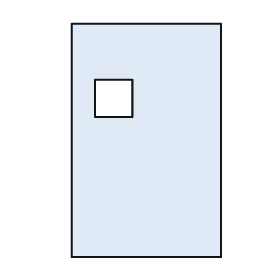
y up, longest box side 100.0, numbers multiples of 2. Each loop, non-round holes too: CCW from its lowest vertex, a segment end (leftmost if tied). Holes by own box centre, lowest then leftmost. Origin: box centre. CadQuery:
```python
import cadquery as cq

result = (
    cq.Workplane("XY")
    .moveTo(-32.0, -50.0)
    .lineTo(32.0, -50.0)
    .lineTo(32.0, 50.0)
    .lineTo(-32.0, 50.0)
    .close()
    .moveTo(-22.0, 10.0)
    .lineTo(-6.0, 10.0)
    .lineTo(-6.0, 26.0)
    .lineTo(-22.0, 26.0)
    .close()
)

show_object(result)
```